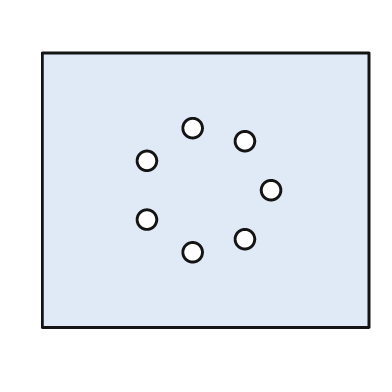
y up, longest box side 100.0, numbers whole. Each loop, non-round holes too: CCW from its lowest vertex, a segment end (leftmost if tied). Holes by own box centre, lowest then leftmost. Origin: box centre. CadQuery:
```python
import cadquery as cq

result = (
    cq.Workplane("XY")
    .moveTo(-50.0, -42.0)
    .lineTo(50.0, -42.0)
    .lineTo(50.0, 42.0)
    .lineTo(-50.0, 42.0)
    .close()
    .moveTo(-4.0, -19.0)
    .circle(3.0)
    .moveTo(12.0, -15.0)
    .circle(3.0)
    .moveTo(-18.0, -9.0)
    .circle(3.0)
    .moveTo(20.0, 0.0)
    .circle(3.0)
    .moveTo(-18.0, 9.0)
    .circle(3.0)
    .moveTo(12.0, 15.0)
    .circle(3.0)
    .moveTo(-4.0, 19.0)
    .circle(3.0)
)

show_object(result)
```